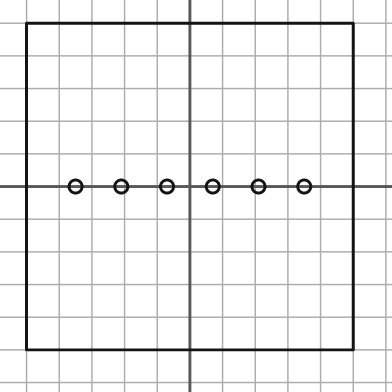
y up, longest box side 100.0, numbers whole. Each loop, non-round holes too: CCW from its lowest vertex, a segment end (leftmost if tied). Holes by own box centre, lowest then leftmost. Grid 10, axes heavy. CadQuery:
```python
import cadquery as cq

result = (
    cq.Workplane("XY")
    .moveTo(-50.0, -50.0)
    .lineTo(50.0, -50.0)
    .lineTo(50.0, 50.0)
    .lineTo(-50.0, 50.0)
    .close()
    .moveTo(-35.0, 0.0)
    .circle(2.0)
    .moveTo(-21.0, 0.0)
    .circle(2.0)
    .moveTo(-7.0, 0.0)
    .circle(2.0)
    .moveTo(7.0, 0.0)
    .circle(2.0)
    .moveTo(21.0, 0.0)
    .circle(2.0)
    .moveTo(35.0, 0.0)
    .circle(2.0)
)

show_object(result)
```